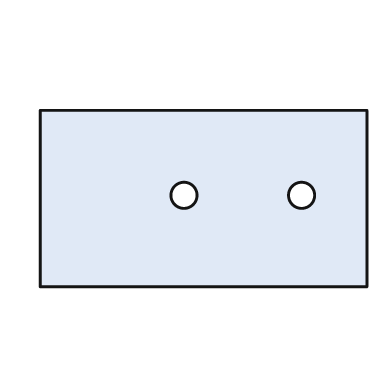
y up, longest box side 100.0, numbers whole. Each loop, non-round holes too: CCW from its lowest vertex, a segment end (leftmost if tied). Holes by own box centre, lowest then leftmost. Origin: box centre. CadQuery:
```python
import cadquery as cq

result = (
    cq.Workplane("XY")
    .moveTo(-50.0, -27.0)
    .lineTo(50.0, -27.0)
    .lineTo(50.0, 27.0)
    .lineTo(-50.0, 27.0)
    .close()
    .moveTo(-6.0, 1.0)
    .circle(4.0)
    .moveTo(30.0, 1.0)
    .circle(4.0)
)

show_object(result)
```